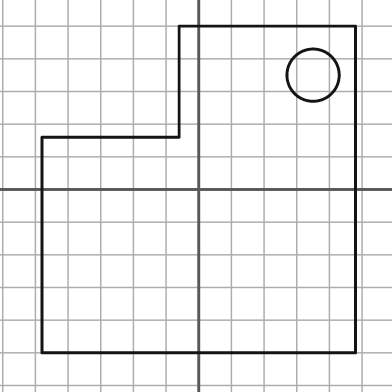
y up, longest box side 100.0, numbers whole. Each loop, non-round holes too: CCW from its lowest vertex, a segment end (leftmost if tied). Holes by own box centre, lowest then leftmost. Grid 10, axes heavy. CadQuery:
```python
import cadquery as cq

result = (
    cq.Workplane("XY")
    .moveTo(-48.0, -50.0)
    .lineTo(48.0, -50.0)
    .lineTo(48.0, 50.0)
    .lineTo(-6.0, 50.0)
    .lineTo(-6.0, 16.0)
    .lineTo(-48.0, 16.0)
    .close()
    .moveTo(35.0, 35.0)
    .circle(8.0)
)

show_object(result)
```